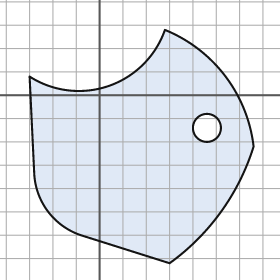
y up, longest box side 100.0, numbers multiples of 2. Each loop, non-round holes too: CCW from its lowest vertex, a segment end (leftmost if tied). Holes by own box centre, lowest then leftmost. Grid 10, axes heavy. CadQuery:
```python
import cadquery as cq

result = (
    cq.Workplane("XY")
    .moveTo(30.0, -72.0)
    .threePointArc((52.0, -50.0), (66.0, -22.0))
    .threePointArc((54.0, 8.0), (28.0, 28.0))
    .threePointArc((4.0, 4.0), (-30.0, 8.0))
    .lineTo(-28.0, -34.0)
    .threePointArc((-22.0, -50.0), (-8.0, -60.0))
    .close()
    .moveTo(46.0, -14.0)
    .circle(6.0)
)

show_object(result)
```